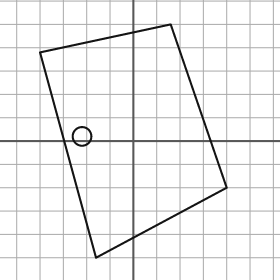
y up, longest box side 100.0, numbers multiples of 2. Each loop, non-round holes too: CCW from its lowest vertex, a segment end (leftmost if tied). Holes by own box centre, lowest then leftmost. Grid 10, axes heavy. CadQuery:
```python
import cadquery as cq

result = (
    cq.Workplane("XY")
    .moveTo(-16.0, -50.0)
    .lineTo(40.0, -20.0)
    .lineTo(16.0, 50.0)
    .lineTo(-40.0, 38.0)
    .close()
    .moveTo(-22.0, 2.0)
    .circle(4.0)
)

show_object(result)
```